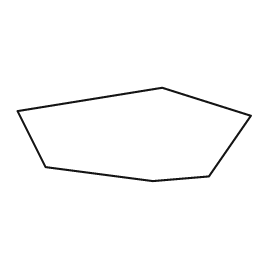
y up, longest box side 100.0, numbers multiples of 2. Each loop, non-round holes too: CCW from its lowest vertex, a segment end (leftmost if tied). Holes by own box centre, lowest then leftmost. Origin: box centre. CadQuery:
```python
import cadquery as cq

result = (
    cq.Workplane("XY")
    .moveTo(8.0, -20.0)
    .lineTo(32.0, -18.0)
    .lineTo(50.0, 8.0)
    .lineTo(12.0, 20.0)
    .lineTo(-50.0, 10.0)
    .lineTo(-38.0, -14.0)
    .close()
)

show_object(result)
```